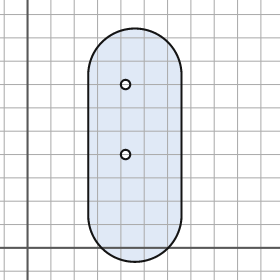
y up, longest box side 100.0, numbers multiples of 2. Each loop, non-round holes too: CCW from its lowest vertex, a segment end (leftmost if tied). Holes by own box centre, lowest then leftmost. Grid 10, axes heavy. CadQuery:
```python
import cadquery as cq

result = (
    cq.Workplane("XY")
    .moveTo(26.0, 14.0)
    .threePointArc((46.0, -6.0), (66.0, 14.0))
    .lineTo(66.0, 74.0)
    .threePointArc((46.0, 94.0), (26.0, 74.0))
    .close()
    .moveTo(42.0, 40.0)
    .circle(2.0)
    .moveTo(42.0, 70.0)
    .circle(2.0)
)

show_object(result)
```